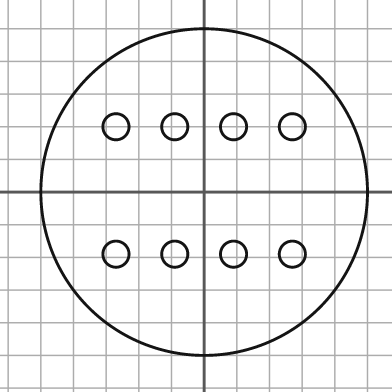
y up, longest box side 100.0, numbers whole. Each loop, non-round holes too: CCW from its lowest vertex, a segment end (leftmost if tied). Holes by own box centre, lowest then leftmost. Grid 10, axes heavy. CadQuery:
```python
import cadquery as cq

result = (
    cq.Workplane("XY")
    .moveTo(0.0, 0.0)
    .circle(50.0)
    .moveTo(-27.0, -19.0)
    .circle(4.0)
    .moveTo(-9.0, -19.0)
    .circle(4.0)
    .moveTo(9.0, -19.0)
    .circle(4.0)
    .moveTo(27.0, -19.0)
    .circle(4.0)
    .moveTo(-27.0, 20.0)
    .circle(4.0)
    .moveTo(-9.0, 20.0)
    .circle(4.0)
    .moveTo(9.0, 20.0)
    .circle(4.0)
    .moveTo(27.0, 20.0)
    .circle(4.0)
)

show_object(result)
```